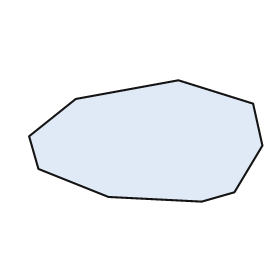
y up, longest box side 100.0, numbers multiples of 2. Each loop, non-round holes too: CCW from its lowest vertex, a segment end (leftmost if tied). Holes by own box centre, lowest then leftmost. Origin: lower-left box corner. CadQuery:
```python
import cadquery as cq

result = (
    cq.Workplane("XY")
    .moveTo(74.0, 0.0)
    .lineTo(88.0, 4.0)
    .lineTo(100.0, 24.0)
    .lineTo(96.0, 42.0)
    .lineTo(64.0, 52.0)
    .lineTo(20.0, 44.0)
    .lineTo(0.0, 28.0)
    .lineTo(4.0, 14.0)
    .lineTo(34.0, 2.0)
    .close()
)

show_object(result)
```